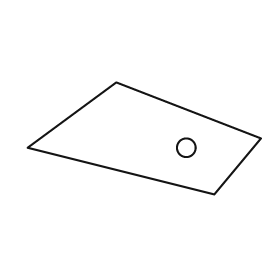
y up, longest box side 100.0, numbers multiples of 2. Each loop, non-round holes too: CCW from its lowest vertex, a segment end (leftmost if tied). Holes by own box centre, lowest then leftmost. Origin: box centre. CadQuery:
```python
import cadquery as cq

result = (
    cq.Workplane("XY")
    .moveTo(30.0, -24.0)
    .lineTo(50.0, 0.0)
    .lineTo(-12.0, 24.0)
    .lineTo(-50.0, -4.0)
    .close()
    .moveTo(18.0, -4.0)
    .circle(4.0)
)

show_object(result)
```